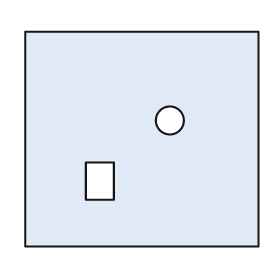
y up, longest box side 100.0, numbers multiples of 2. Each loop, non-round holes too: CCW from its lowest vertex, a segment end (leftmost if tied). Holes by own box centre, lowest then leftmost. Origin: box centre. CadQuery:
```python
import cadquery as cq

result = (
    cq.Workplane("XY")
    .moveTo(-50.0, -46.0)
    .lineTo(50.0, -46.0)
    .lineTo(50.0, 46.0)
    .lineTo(-50.0, 46.0)
    .close()
    .moveTo(-24.0, -26.0)
    .lineTo(-12.0, -26.0)
    .lineTo(-12.0, -10.0)
    .lineTo(-24.0, -10.0)
    .close()
    .moveTo(12.0, 8.0)
    .circle(6.0)
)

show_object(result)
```